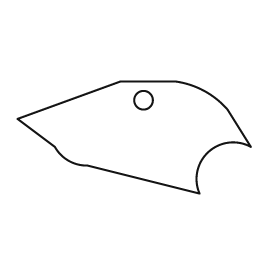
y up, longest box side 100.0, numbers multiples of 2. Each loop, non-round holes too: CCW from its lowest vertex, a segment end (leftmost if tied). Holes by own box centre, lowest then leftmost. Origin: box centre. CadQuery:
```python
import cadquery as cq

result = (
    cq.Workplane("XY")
    .moveTo(28.0, -24.0)
    .threePointArc((32.0, -6.0), (50.0, -4.0))
    .lineTo(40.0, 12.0)
    .threePointArc((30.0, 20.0), (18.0, 24.0))
    .lineTo(-6.0, 24.0)
    .lineTo(-50.0, 8.0)
    .lineTo(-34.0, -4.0)
    .threePointArc((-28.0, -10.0), (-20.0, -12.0))
    .close()
    .moveTo(4.0, 16.0)
    .circle(4.0)
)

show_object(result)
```